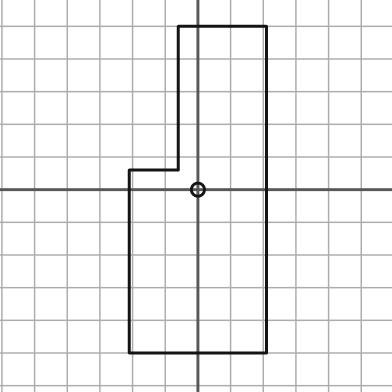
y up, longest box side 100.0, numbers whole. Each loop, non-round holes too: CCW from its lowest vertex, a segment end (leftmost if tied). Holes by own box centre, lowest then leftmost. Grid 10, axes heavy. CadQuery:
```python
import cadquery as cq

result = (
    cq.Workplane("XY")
    .moveTo(-21.0, -50.0)
    .lineTo(21.0, -50.0)
    .lineTo(21.0, 50.0)
    .lineTo(-6.0, 50.0)
    .lineTo(-6.0, 6.0)
    .lineTo(-21.0, 6.0)
    .close()
    .moveTo(0.0, 0.0)
    .circle(2.0)
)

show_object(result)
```